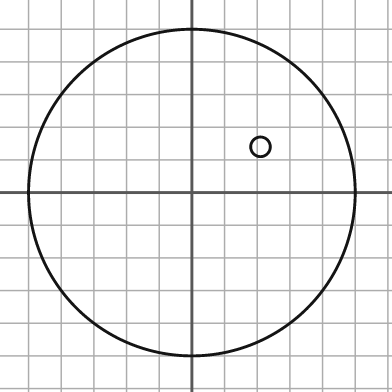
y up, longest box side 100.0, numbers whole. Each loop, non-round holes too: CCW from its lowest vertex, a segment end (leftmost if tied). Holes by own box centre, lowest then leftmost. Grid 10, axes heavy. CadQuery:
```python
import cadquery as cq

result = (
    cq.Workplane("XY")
    .moveTo(0.0, 0.0)
    .circle(50.0)
    .moveTo(21.0, 14.0)
    .circle(3.0)
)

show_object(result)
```